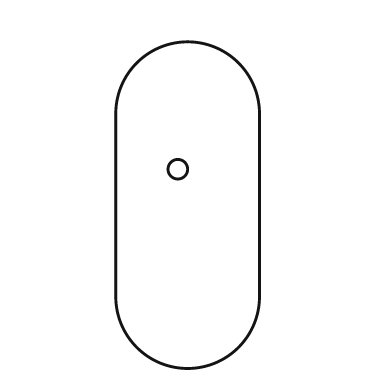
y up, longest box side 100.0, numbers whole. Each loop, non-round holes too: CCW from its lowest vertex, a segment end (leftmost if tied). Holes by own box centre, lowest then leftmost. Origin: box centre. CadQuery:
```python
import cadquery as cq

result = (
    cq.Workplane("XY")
    .moveTo(-22.0, -28.0)
    .threePointArc((0.0, -50.0), (22.0, -28.0))
    .lineTo(22.0, 28.0)
    .threePointArc((0.0, 50.0), (-22.0, 28.0))
    .close()
    .moveTo(-3.0, 11.0)
    .circle(3.0)
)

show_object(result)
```